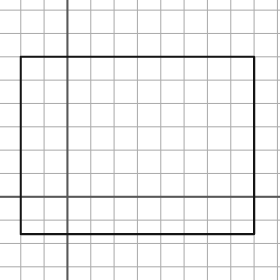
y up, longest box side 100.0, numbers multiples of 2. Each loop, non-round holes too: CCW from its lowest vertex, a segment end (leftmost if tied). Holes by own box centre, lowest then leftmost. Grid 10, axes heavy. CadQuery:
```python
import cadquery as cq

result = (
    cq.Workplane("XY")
    .moveTo(-20.0, -16.0)
    .lineTo(80.0, -16.0)
    .lineTo(80.0, 60.0)
    .lineTo(-20.0, 60.0)
    .close()
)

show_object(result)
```